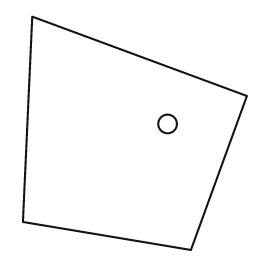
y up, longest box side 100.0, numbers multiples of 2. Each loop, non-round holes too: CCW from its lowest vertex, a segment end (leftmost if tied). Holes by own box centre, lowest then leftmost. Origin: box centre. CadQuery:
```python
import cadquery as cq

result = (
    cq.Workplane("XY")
    .moveTo(24.0, -50.0)
    .lineTo(48.0, 16.0)
    .lineTo(-44.0, 50.0)
    .lineTo(-48.0, -38.0)
    .close()
    .moveTo(14.0, 4.0)
    .circle(4.0)
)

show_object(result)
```